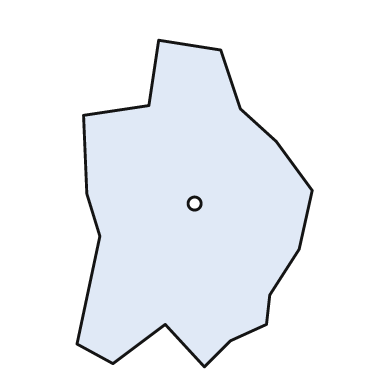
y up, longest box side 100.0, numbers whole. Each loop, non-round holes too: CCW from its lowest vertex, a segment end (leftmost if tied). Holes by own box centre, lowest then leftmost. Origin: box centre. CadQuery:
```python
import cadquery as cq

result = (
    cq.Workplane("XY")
    .moveTo(3.0, -50.0)
    .lineTo(11.0, -42.0)
    .lineTo(22.0, -37.0)
    .lineTo(23.0, -28.0)
    .lineTo(32.0, -14.0)
    .lineTo(36.0, 4.0)
    .lineTo(25.0, 19.0)
    .lineTo(14.0, 29.0)
    .lineTo(8.0, 47.0)
    .lineTo(-11.0, 50.0)
    .lineTo(-14.0, 30.0)
    .lineTo(-34.0, 27.0)
    .lineTo(-33.0, 3.0)
    .lineTo(-29.0, -10.0)
    .lineTo(-36.0, -43.0)
    .lineTo(-25.0, -49.0)
    .lineTo(-9.0, -37.0)
    .close()
    .moveTo(0.0, 0.0)
    .circle(2.0)
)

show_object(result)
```